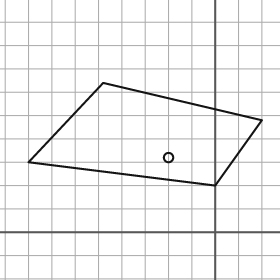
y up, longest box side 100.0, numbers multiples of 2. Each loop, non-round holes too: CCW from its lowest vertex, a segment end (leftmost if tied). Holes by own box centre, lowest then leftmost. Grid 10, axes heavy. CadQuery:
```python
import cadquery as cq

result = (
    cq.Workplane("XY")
    .moveTo(0.0, 20.0)
    .lineTo(20.0, 48.0)
    .lineTo(-48.0, 64.0)
    .lineTo(-80.0, 30.0)
    .close()
    .moveTo(-20.0, 32.0)
    .circle(2.0)
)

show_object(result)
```